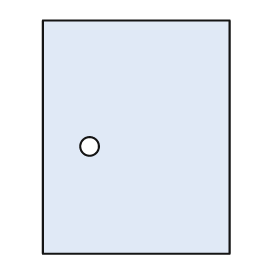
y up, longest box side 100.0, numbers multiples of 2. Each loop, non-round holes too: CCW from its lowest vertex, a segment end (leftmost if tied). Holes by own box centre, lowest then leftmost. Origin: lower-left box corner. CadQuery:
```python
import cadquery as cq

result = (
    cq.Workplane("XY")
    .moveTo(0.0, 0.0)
    .lineTo(80.0, 0.0)
    .lineTo(80.0, 100.0)
    .lineTo(0.0, 100.0)
    .close()
    .moveTo(20.0, 46.0)
    .circle(4.0)
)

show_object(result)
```